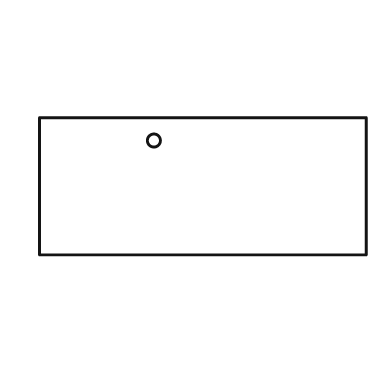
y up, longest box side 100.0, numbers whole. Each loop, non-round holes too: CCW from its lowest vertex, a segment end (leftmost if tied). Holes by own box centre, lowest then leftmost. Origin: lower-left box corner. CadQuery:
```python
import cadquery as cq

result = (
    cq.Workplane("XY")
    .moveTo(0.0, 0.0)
    .lineTo(100.0, 0.0)
    .lineTo(100.0, 42.0)
    .lineTo(0.0, 42.0)
    .close()
    .moveTo(35.0, 35.0)
    .circle(2.0)
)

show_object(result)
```